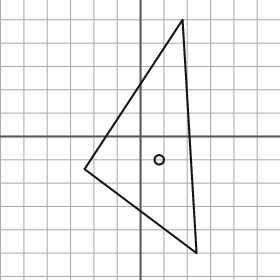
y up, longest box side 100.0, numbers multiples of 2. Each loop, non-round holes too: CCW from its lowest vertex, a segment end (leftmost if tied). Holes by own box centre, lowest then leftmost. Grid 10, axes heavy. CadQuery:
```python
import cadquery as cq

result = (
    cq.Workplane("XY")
    .moveTo(24.0, -50.0)
    .lineTo(18.0, 50.0)
    .lineTo(-24.0, -14.0)
    .close()
    .moveTo(8.0, -10.0)
    .circle(2.0)
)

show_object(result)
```